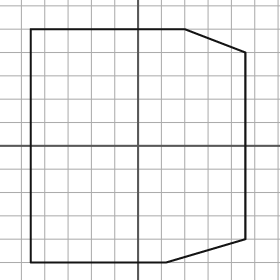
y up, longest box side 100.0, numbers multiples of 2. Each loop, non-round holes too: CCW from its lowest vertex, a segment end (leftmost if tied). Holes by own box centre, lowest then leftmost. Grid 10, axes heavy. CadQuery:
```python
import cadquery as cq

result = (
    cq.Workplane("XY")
    .moveTo(-46.0, -50.0)
    .lineTo(12.0, -50.0)
    .lineTo(46.0, -40.0)
    .lineTo(46.0, 40.0)
    .lineTo(20.0, 50.0)
    .lineTo(-46.0, 50.0)
    .close()
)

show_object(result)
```